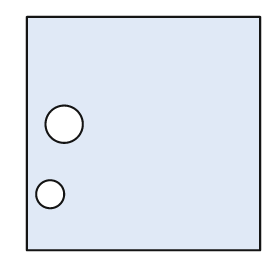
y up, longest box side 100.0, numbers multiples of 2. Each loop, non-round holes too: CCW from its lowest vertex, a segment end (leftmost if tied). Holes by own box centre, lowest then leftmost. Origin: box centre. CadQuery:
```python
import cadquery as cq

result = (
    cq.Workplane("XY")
    .moveTo(-50.0, -50.0)
    .lineTo(50.0, -50.0)
    .lineTo(50.0, 50.0)
    .lineTo(-50.0, 50.0)
    .close()
    .moveTo(-40.0, -26.0)
    .circle(6.0)
    .moveTo(-34.0, 4.0)
    .circle(8.0)
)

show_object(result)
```